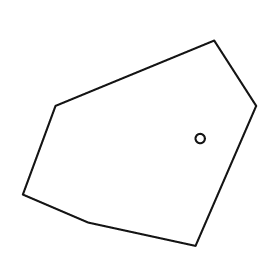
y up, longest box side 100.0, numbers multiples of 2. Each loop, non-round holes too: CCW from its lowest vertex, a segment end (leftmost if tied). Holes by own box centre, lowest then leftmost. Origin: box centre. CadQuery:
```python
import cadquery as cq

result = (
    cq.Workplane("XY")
    .moveTo(24.0, -44.0)
    .lineTo(50.0, 16.0)
    .lineTo(32.0, 44.0)
    .lineTo(-36.0, 16.0)
    .lineTo(-50.0, -22.0)
    .lineTo(-22.0, -34.0)
    .close()
    .moveTo(26.0, 2.0)
    .circle(2.0)
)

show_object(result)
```